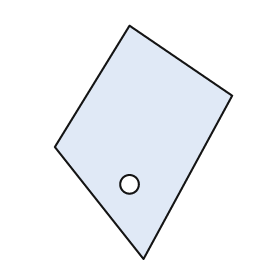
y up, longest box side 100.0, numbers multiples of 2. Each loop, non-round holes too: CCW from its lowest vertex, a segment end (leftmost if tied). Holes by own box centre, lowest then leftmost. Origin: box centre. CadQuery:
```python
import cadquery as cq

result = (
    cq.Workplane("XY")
    .moveTo(0.0, -50.0)
    .lineTo(38.0, 20.0)
    .lineTo(-6.0, 50.0)
    .lineTo(-38.0, -2.0)
    .close()
    .moveTo(-6.0, -18.0)
    .circle(4.0)
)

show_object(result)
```